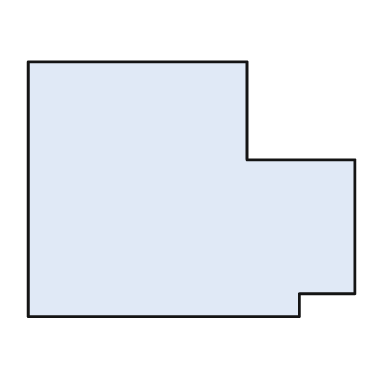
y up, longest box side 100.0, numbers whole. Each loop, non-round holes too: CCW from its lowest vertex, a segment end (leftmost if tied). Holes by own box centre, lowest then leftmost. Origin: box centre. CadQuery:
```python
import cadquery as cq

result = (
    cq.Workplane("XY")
    .moveTo(-50.0, -39.0)
    .lineTo(33.0, -39.0)
    .lineTo(33.0, -32.0)
    .lineTo(50.0, -32.0)
    .lineTo(50.0, 9.0)
    .lineTo(17.0, 9.0)
    .lineTo(17.0, 39.0)
    .lineTo(-50.0, 39.0)
    .close()
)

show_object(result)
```